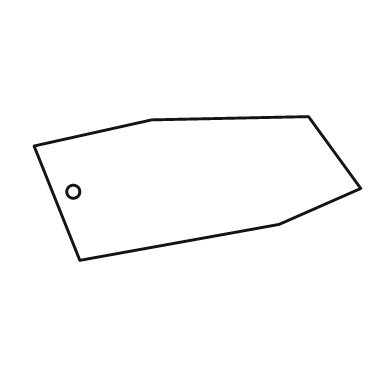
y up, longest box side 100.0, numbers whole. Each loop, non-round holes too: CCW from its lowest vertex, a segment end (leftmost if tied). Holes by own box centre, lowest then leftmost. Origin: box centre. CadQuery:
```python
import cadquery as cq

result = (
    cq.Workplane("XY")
    .moveTo(-36.0, -22.0)
    .lineTo(25.0, -11.0)
    .lineTo(50.0, 0.0)
    .lineTo(34.0, 22.0)
    .lineTo(-14.0, 21.0)
    .lineTo(-50.0, 13.0)
    .close()
    .moveTo(-38.0, -1.0)
    .circle(2.0)
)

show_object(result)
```